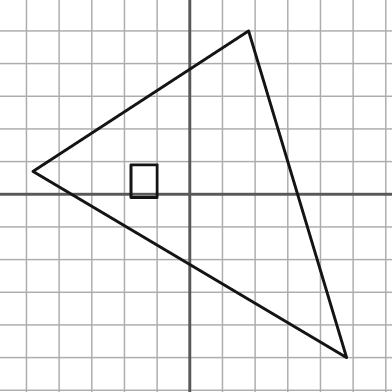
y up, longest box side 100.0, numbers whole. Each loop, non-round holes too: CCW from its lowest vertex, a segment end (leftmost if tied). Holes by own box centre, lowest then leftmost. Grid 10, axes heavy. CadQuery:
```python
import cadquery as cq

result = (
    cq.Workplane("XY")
    .moveTo(48.0, -50.0)
    .lineTo(18.0, 50.0)
    .lineTo(-48.0, 7.0)
    .close()
    .moveTo(-18.0, -1.0)
    .lineTo(-10.0, -1.0)
    .lineTo(-10.0, 9.0)
    .lineTo(-18.0, 9.0)
    .close()
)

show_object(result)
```